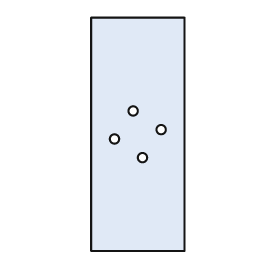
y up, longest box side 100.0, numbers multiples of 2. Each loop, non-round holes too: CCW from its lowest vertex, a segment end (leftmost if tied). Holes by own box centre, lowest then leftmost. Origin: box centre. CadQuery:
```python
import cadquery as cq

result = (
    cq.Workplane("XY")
    .moveTo(-20.0, -50.0)
    .lineTo(20.0, -50.0)
    .lineTo(20.0, 50.0)
    .lineTo(-20.0, 50.0)
    .close()
    .moveTo(2.0, -10.0)
    .circle(2.0)
    .moveTo(-10.0, -2.0)
    .circle(2.0)
    .moveTo(10.0, 2.0)
    .circle(2.0)
    .moveTo(-2.0, 10.0)
    .circle(2.0)
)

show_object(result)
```